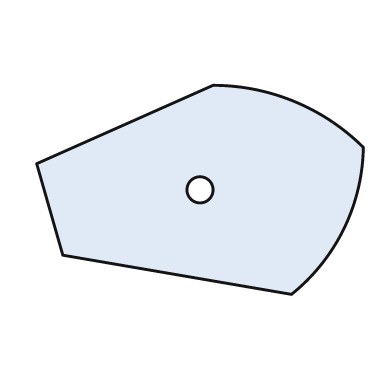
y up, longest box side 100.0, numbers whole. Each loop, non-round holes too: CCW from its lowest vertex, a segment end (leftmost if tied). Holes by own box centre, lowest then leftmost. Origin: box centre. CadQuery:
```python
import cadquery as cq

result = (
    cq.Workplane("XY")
    .moveTo(28.0, -32.0)
    .threePointArc((44.0, -12.0), (50.0, 13.0))
    .threePointArc((29.0, 27.0), (4.0, 32.0))
    .lineTo(-50.0, 8.0)
    .lineTo(-42.0, -20.0)
    .close()
    .moveTo(0.0, 0.0)
    .circle(4.0)
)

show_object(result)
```